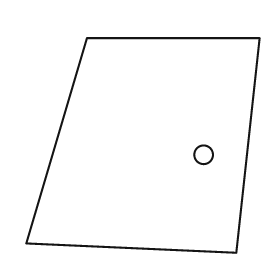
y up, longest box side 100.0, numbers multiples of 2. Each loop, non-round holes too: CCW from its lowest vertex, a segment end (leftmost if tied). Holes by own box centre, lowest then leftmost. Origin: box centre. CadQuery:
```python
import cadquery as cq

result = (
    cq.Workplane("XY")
    .moveTo(40.0, -46.0)
    .lineTo(50.0, 46.0)
    .lineTo(-24.0, 46.0)
    .lineTo(-50.0, -42.0)
    .close()
    .moveTo(26.0, -4.0)
    .circle(4.0)
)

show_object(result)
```